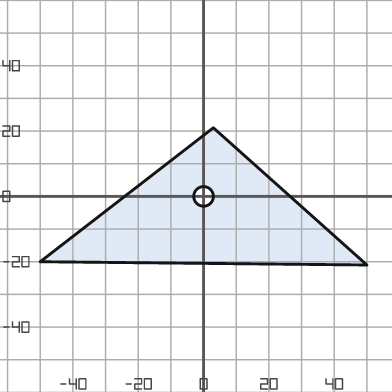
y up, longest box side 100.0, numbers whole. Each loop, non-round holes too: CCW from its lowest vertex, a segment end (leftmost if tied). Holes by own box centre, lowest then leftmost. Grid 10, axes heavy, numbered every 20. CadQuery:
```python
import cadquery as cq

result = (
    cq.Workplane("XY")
    .moveTo(50.0, -21.0)
    .lineTo(3.0, 21.0)
    .lineTo(-50.0, -20.0)
    .close()
    .moveTo(0.0, 0.0)
    .circle(3.0)
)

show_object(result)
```